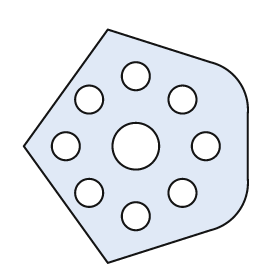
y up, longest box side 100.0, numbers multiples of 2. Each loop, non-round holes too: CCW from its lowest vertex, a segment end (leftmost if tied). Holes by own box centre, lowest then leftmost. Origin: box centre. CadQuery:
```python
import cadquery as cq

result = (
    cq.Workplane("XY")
    .moveTo(-12.0, -50.0)
    .lineTo(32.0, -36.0)
    .threePointArc((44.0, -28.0), (48.0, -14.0))
    .lineTo(48.0, 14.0)
    .threePointArc((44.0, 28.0), (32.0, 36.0))
    .lineTo(-12.0, 50.0)
    .lineTo(-48.0, 0.0)
    .close()
    .moveTo(0.0, -30.0)
    .circle(6.0)
    .moveTo(-20.0, -20.0)
    .circle(6.0)
    .moveTo(20.0, -20.0)
    .circle(6.0)
    .moveTo(-30.0, 0.0)
    .circle(6.0)
    .moveTo(0.0, 0.0)
    .circle(10.0)
    .moveTo(30.0, 0.0)
    .circle(6.0)
    .moveTo(-20.0, 20.0)
    .circle(6.0)
    .moveTo(20.0, 20.0)
    .circle(6.0)
    .moveTo(0.0, 30.0)
    .circle(6.0)
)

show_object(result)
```